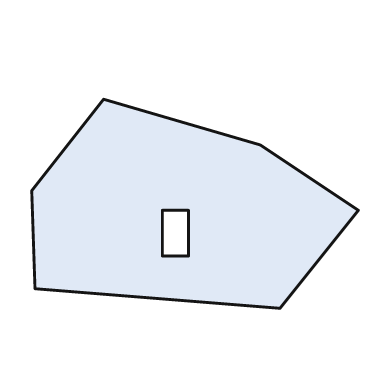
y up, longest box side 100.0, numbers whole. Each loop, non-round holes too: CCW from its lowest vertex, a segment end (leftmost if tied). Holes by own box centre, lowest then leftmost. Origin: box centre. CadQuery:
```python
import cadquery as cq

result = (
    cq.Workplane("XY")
    .moveTo(26.0, -32.0)
    .lineTo(50.0, -2.0)
    .lineTo(20.0, 18.0)
    .lineTo(-28.0, 32.0)
    .lineTo(-50.0, 4.0)
    .lineTo(-49.0, -26.0)
    .close()
    .moveTo(-10.0, -16.0)
    .lineTo(-2.0, -16.0)
    .lineTo(-2.0, -2.0)
    .lineTo(-10.0, -2.0)
    .close()
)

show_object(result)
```